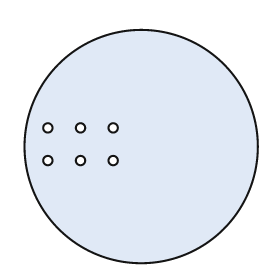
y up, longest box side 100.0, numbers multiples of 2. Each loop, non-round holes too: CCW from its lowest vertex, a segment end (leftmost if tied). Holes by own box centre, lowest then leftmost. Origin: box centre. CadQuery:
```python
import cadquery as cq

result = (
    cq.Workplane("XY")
    .moveTo(0.0, 0.0)
    .circle(50.0)
    .moveTo(-40.0, -6.0)
    .circle(2.0)
    .moveTo(-26.0, -6.0)
    .circle(2.0)
    .moveTo(-12.0, -6.0)
    .circle(2.0)
    .moveTo(-40.0, 8.0)
    .circle(2.0)
    .moveTo(-26.0, 8.0)
    .circle(2.0)
    .moveTo(-12.0, 8.0)
    .circle(2.0)
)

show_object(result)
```